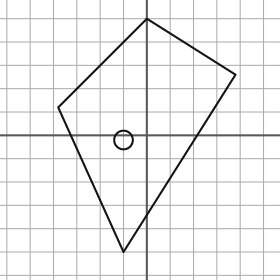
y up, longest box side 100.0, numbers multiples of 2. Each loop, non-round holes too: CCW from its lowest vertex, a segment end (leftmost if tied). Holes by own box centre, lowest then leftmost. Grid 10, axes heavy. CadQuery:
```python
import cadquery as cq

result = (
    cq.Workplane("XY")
    .moveTo(-10.0, -50.0)
    .lineTo(38.0, 26.0)
    .lineTo(0.0, 50.0)
    .lineTo(-38.0, 12.0)
    .close()
    .moveTo(-10.0, -2.0)
    .circle(4.0)
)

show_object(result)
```